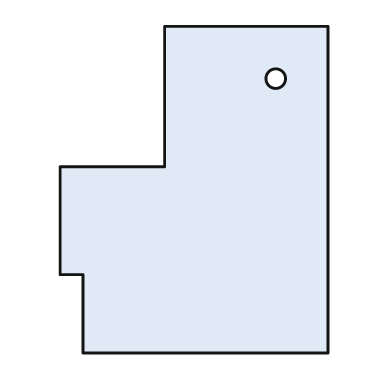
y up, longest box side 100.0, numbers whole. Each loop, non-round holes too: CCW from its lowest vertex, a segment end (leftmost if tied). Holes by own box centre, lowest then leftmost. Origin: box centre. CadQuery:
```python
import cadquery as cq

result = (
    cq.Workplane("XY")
    .moveTo(-34.0, -50.0)
    .lineTo(41.0, -50.0)
    .lineTo(41.0, 50.0)
    .lineTo(-9.0, 50.0)
    .lineTo(-9.0, 7.0)
    .lineTo(-41.0, 7.0)
    .lineTo(-41.0, -26.0)
    .lineTo(-34.0, -26.0)
    .close()
    .moveTo(25.0, 34.0)
    .circle(3.0)
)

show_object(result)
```